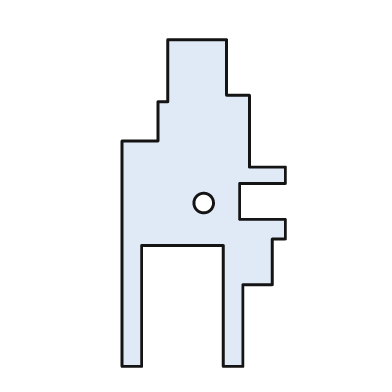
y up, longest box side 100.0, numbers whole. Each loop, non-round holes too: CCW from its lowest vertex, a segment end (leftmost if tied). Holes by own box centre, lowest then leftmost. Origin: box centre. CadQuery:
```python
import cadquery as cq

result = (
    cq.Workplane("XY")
    .moveTo(-25.0, -50.0)
    .lineTo(-19.0, -50.0)
    .lineTo(-19.0, -13.0)
    .lineTo(6.0, -13.0)
    .lineTo(6.0, -50.0)
    .lineTo(12.0, -50.0)
    .lineTo(12.0, -25.0)
    .lineTo(21.0, -25.0)
    .lineTo(21.0, -11.0)
    .lineTo(25.0, -11.0)
    .lineTo(25.0, -5.0)
    .lineTo(11.0, -5.0)
    .lineTo(11.0, 6.0)
    .lineTo(25.0, 6.0)
    .lineTo(25.0, 11.0)
    .lineTo(14.0, 11.0)
    .lineTo(14.0, 33.0)
    .lineTo(7.0, 33.0)
    .lineTo(7.0, 50.0)
    .lineTo(-11.0, 50.0)
    .lineTo(-11.0, 31.0)
    .lineTo(-14.0, 31.0)
    .lineTo(-14.0, 19.0)
    .lineTo(-25.0, 19.0)
    .close()
    .moveTo(0.0, 0.0)
    .circle(3.0)
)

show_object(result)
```